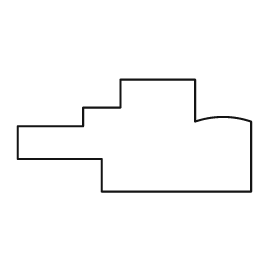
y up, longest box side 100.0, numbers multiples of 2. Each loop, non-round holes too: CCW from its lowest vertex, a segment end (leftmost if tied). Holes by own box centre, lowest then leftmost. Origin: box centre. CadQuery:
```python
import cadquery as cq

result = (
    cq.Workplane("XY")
    .moveTo(-14.0, -24.0)
    .lineTo(50.0, -24.0)
    .lineTo(50.0, 6.0)
    .threePointArc((38.0, 8.0), (26.0, 6.0))
    .lineTo(26.0, 24.0)
    .lineTo(-6.0, 24.0)
    .lineTo(-6.0, 12.0)
    .lineTo(-22.0, 12.0)
    .lineTo(-22.0, 4.0)
    .lineTo(-50.0, 4.0)
    .lineTo(-50.0, -10.0)
    .lineTo(-14.0, -10.0)
    .close()
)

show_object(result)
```